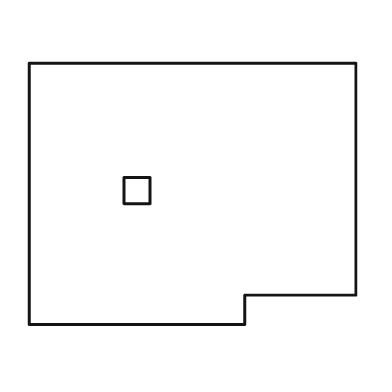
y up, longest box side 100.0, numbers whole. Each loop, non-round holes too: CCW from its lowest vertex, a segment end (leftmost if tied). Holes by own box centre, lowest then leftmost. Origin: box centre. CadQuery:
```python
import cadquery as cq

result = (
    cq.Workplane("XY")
    .moveTo(-50.0, -40.0)
    .lineTo(16.0, -40.0)
    .lineTo(16.0, -31.0)
    .lineTo(50.0, -31.0)
    .lineTo(50.0, 40.0)
    .lineTo(-50.0, 40.0)
    .close()
    .moveTo(-21.0, -3.0)
    .lineTo(-13.0, -3.0)
    .lineTo(-13.0, 5.0)
    .lineTo(-21.0, 5.0)
    .close()
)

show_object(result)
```